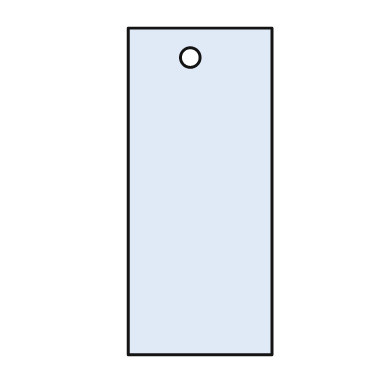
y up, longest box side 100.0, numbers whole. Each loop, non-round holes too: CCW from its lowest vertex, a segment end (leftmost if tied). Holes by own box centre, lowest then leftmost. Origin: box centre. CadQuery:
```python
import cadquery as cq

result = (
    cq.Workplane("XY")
    .moveTo(-22.0, -50.0)
    .lineTo(22.0, -50.0)
    .lineTo(22.0, 50.0)
    .lineTo(-22.0, 50.0)
    .close()
    .moveTo(-3.0, 41.0)
    .circle(3.0)
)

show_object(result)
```